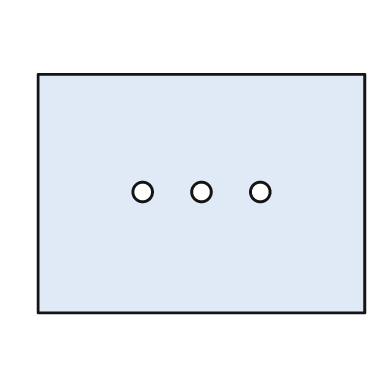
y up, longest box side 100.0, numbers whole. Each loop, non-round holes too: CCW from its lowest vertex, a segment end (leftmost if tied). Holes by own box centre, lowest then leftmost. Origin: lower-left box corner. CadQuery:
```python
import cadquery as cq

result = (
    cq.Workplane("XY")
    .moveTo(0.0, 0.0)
    .lineTo(100.0, 0.0)
    .lineTo(100.0, 73.0)
    .lineTo(0.0, 73.0)
    .close()
    .moveTo(32.0, 37.0)
    .circle(3.0)
    .moveTo(50.0, 37.0)
    .circle(3.0)
    .moveTo(68.0, 37.0)
    .circle(3.0)
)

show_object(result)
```